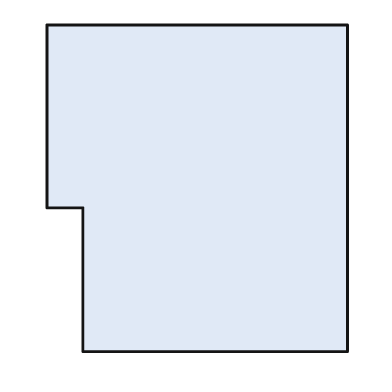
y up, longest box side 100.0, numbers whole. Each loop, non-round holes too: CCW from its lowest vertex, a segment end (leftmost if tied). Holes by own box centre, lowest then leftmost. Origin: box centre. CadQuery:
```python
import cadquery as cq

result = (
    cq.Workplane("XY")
    .moveTo(-35.0, -50.0)
    .lineTo(46.0, -50.0)
    .lineTo(46.0, 50.0)
    .lineTo(-46.0, 50.0)
    .lineTo(-46.0, -6.0)
    .lineTo(-35.0, -6.0)
    .close()
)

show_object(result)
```